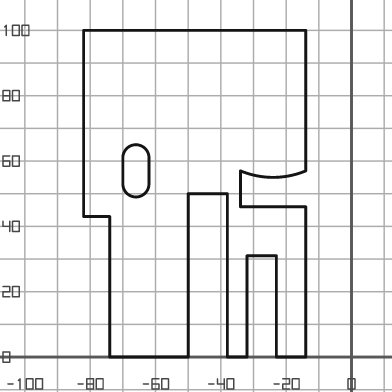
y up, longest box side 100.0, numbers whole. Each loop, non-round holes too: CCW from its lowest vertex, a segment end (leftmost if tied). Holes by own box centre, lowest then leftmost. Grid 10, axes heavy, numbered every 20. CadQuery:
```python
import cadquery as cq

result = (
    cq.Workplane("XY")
    .moveTo(-74.0, 0.0)
    .lineTo(-50.0, 0.0)
    .lineTo(-50.0, 50.0)
    .lineTo(-38.0, 50.0)
    .lineTo(-38.0, 0.0)
    .lineTo(-32.0, 0.0)
    .lineTo(-32.0, 31.0)
    .lineTo(-23.0, 31.0)
    .lineTo(-23.0, 0.0)
    .lineTo(-14.0, 0.0)
    .lineTo(-14.0, 46.0)
    .lineTo(-34.0, 46.0)
    .lineTo(-34.0, 57.0)
    .threePointArc((-24.0, 55.0), (-14.0, 57.0))
    .lineTo(-14.0, 100.0)
    .lineTo(-82.0, 100.0)
    .lineTo(-82.0, 43.0)
    .lineTo(-74.0, 43.0)
    .close()
    .moveTo(-70.0, 53.0)
    .threePointArc((-66.0, 49.0), (-62.0, 53.0))
    .lineTo(-62.0, 61.0)
    .threePointArc((-66.0, 65.0), (-70.0, 61.0))
    .close()
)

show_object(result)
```